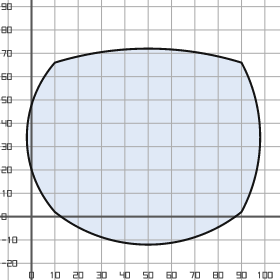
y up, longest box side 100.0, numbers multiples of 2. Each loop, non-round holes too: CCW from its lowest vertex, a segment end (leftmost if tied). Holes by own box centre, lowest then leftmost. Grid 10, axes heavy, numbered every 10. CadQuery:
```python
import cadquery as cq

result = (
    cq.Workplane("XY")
    .moveTo(10.0, 2.0)
    .threePointArc((50.0, -12.0), (90.0, 2.0))
    .threePointArc((98.0, 34.0), (90.0, 66.0))
    .threePointArc((50.0, 72.0), (10.0, 66.0))
    .threePointArc((-2.0, 34.0), (10.0, 2.0))
    .close()
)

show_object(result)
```